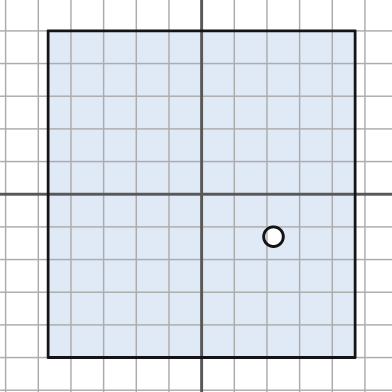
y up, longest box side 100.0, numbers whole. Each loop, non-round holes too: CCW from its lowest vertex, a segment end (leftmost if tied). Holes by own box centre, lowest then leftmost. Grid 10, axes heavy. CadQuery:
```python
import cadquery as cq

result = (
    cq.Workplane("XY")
    .moveTo(-47.0, -50.0)
    .lineTo(47.0, -50.0)
    .lineTo(47.0, 50.0)
    .lineTo(-47.0, 50.0)
    .close()
    .moveTo(22.0, -13.0)
    .circle(3.0)
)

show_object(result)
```